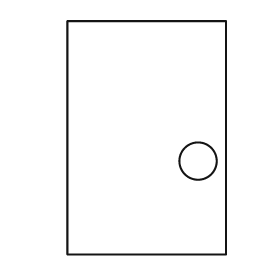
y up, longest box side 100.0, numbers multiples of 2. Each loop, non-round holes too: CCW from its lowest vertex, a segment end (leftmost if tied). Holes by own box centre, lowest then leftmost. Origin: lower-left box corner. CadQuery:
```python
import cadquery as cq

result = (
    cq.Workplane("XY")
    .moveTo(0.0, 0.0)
    .lineTo(68.0, 0.0)
    .lineTo(68.0, 100.0)
    .lineTo(0.0, 100.0)
    .close()
    .moveTo(56.0, 40.0)
    .circle(8.0)
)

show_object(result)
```